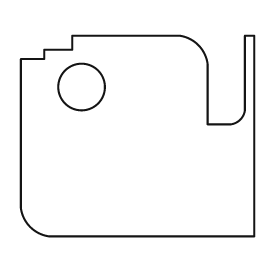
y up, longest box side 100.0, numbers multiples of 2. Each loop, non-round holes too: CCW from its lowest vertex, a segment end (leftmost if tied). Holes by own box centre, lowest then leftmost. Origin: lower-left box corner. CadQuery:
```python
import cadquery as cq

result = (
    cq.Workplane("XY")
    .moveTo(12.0, 0.0)
    .lineTo(100.0, 0.0)
    .lineTo(100.0, 86.0)
    .lineTo(96.0, 86.0)
    .lineTo(96.0, 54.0)
    .threePointArc((94.0, 50.0), (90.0, 48.0))
    .lineTo(80.0, 48.0)
    .lineTo(80.0, 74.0)
    .threePointArc((76.0, 82.0), (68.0, 86.0))
    .lineTo(22.0, 86.0)
    .lineTo(22.0, 80.0)
    .lineTo(10.0, 80.0)
    .lineTo(10.0, 76.0)
    .lineTo(0.0, 76.0)
    .lineTo(0.0, 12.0)
    .threePointArc((4.0, 4.0), (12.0, 0.0))
    .close()
    .moveTo(26.0, 64.0)
    .circle(10.0)
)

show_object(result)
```